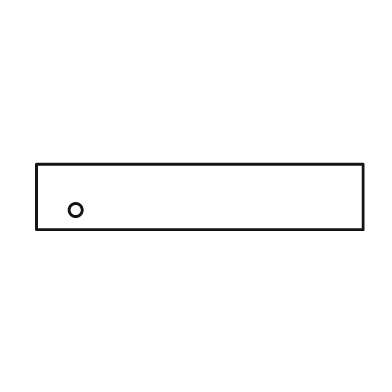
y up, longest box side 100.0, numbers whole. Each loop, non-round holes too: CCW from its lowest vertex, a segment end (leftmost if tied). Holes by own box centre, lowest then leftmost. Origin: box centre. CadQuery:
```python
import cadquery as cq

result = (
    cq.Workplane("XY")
    .moveTo(-50.0, -10.0)
    .lineTo(50.0, -10.0)
    .lineTo(50.0, 10.0)
    .lineTo(-50.0, 10.0)
    .close()
    .moveTo(-38.0, -4.0)
    .circle(2.0)
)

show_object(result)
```